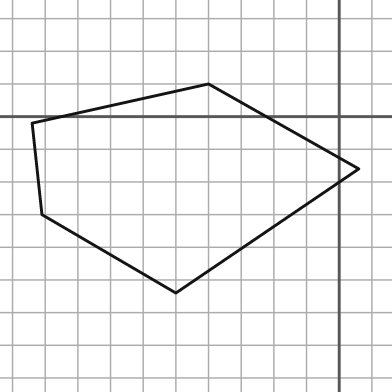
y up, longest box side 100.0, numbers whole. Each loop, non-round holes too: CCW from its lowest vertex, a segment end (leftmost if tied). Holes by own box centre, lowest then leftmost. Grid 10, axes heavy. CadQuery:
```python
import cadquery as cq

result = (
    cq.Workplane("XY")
    .moveTo(-50.0, -54.0)
    .lineTo(6.0, -16.0)
    .lineTo(-40.0, 10.0)
    .lineTo(-94.0, -2.0)
    .lineTo(-91.0, -30.0)
    .close()
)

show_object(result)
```